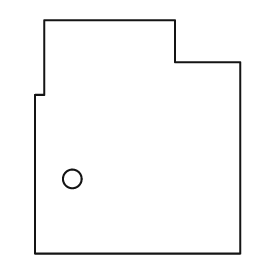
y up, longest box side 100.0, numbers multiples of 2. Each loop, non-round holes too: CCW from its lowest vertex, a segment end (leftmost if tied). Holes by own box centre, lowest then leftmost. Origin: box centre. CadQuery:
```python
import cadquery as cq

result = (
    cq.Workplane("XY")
    .moveTo(-44.0, -50.0)
    .lineTo(44.0, -50.0)
    .lineTo(44.0, 32.0)
    .lineTo(16.0, 32.0)
    .lineTo(16.0, 50.0)
    .lineTo(-40.0, 50.0)
    .lineTo(-40.0, 18.0)
    .lineTo(-44.0, 18.0)
    .close()
    .moveTo(-28.0, -18.0)
    .circle(4.0)
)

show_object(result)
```